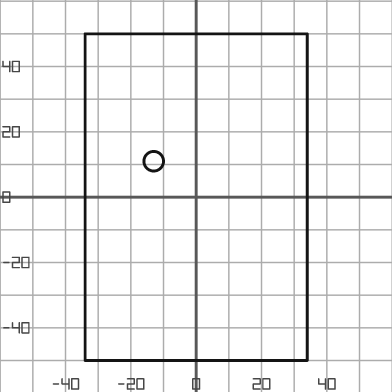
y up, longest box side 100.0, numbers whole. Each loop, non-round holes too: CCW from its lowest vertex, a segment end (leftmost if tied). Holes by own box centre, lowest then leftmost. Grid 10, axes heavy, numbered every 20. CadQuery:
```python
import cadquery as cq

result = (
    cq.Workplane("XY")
    .moveTo(-34.0, -50.0)
    .lineTo(34.0, -50.0)
    .lineTo(34.0, 50.0)
    .lineTo(-34.0, 50.0)
    .close()
    .moveTo(-13.0, 11.0)
    .circle(3.0)
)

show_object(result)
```